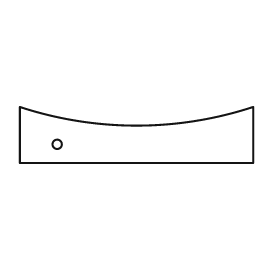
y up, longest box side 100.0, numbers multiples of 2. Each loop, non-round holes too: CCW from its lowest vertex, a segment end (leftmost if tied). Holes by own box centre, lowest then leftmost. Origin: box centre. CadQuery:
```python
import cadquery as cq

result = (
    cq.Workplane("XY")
    .moveTo(-50.0, -12.0)
    .lineTo(50.0, -12.0)
    .lineTo(50.0, 12.0)
    .threePointArc((0.0, 4.0), (-50.0, 12.0))
    .close()
    .moveTo(-34.0, -4.0)
    .circle(2.0)
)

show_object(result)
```